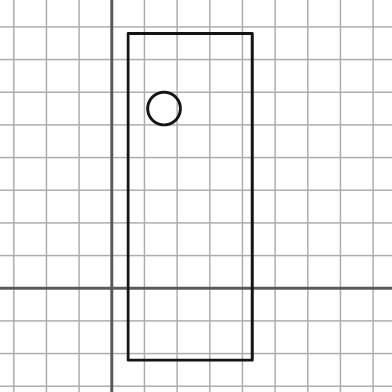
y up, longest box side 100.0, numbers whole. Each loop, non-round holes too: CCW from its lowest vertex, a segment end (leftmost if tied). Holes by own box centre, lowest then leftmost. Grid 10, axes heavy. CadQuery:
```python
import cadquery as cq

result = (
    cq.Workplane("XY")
    .moveTo(5.0, -22.0)
    .lineTo(43.0, -22.0)
    .lineTo(43.0, 78.0)
    .lineTo(5.0, 78.0)
    .close()
    .moveTo(16.0, 55.0)
    .circle(5.0)
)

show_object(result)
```